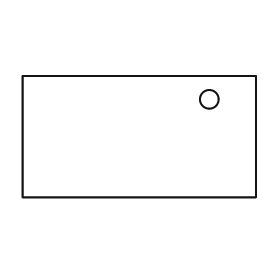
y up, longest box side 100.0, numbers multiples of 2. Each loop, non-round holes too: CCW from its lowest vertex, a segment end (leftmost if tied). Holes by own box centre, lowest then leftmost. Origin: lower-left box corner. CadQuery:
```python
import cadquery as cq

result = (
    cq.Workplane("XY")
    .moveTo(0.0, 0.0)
    .lineTo(100.0, 0.0)
    .lineTo(100.0, 52.0)
    .lineTo(0.0, 52.0)
    .close()
    .moveTo(80.0, 42.0)
    .circle(4.0)
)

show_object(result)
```